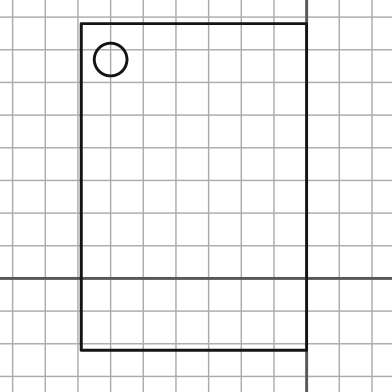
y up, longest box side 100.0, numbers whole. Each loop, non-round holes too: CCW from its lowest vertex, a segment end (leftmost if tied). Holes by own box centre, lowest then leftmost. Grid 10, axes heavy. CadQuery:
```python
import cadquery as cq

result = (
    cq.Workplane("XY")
    .moveTo(-69.0, -22.0)
    .lineTo(0.0, -22.0)
    .lineTo(0.0, 78.0)
    .lineTo(-69.0, 78.0)
    .close()
    .moveTo(-60.0, 67.0)
    .circle(5.0)
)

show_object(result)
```